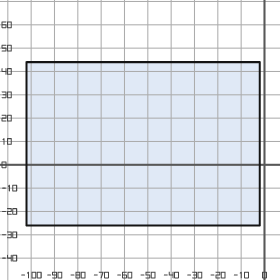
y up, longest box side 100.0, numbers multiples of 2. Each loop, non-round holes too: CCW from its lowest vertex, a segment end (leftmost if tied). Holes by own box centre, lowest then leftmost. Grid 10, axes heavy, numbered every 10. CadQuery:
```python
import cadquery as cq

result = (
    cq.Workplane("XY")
    .moveTo(-102.0, -26.0)
    .lineTo(-2.0, -26.0)
    .lineTo(-2.0, 44.0)
    .lineTo(-102.0, 44.0)
    .close()
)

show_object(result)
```